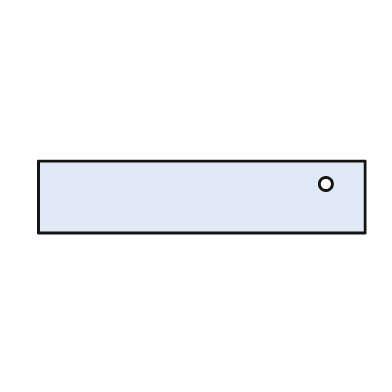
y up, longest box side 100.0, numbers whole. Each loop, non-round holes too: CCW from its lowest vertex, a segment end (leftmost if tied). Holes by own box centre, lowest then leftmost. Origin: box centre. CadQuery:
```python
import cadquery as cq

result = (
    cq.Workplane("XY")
    .moveTo(-50.0, -11.0)
    .lineTo(50.0, -11.0)
    .lineTo(50.0, 11.0)
    .lineTo(-50.0, 11.0)
    .close()
    .moveTo(38.0, 4.0)
    .circle(2.0)
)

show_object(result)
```